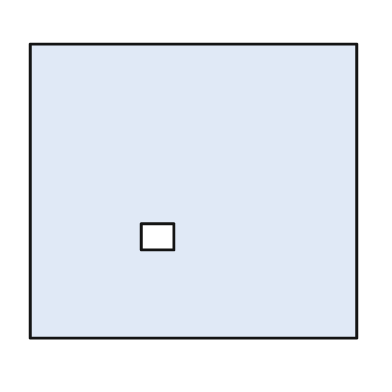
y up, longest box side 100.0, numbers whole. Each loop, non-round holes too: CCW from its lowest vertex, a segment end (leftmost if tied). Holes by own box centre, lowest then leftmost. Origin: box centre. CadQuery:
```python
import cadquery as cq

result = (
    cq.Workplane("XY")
    .moveTo(-50.0, -45.0)
    .lineTo(50.0, -45.0)
    .lineTo(50.0, 45.0)
    .lineTo(-50.0, 45.0)
    .close()
    .moveTo(-16.0, -18.0)
    .lineTo(-6.0, -18.0)
    .lineTo(-6.0, -10.0)
    .lineTo(-16.0, -10.0)
    .close()
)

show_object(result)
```